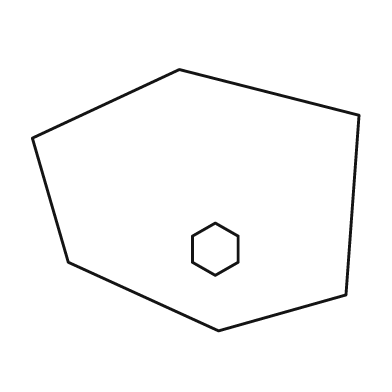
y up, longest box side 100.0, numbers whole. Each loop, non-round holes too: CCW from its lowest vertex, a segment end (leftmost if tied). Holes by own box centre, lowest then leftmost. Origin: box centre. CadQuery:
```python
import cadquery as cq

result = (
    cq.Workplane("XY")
    .moveTo(7.0, -40.0)
    .lineTo(46.0, -29.0)
    .lineTo(50.0, 26.0)
    .lineTo(-5.0, 40.0)
    .lineTo(-50.0, 19.0)
    .lineTo(-39.0, -19.0)
    .close()
    .moveTo(6.0, -23.0)
    .lineTo(13.0, -19.0)
    .lineTo(13.0, -11.0)
    .lineTo(6.0, -7.0)
    .lineTo(-1.0, -11.0)
    .lineTo(-1.0, -19.0)
    .close()
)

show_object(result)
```